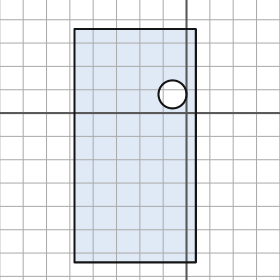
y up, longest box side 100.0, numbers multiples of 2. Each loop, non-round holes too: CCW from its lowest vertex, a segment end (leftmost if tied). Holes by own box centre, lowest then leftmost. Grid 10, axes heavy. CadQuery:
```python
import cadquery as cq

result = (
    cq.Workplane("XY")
    .moveTo(-48.0, -64.0)
    .lineTo(4.0, -64.0)
    .lineTo(4.0, 36.0)
    .lineTo(-48.0, 36.0)
    .close()
    .moveTo(-6.0, 8.0)
    .circle(6.0)
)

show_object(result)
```